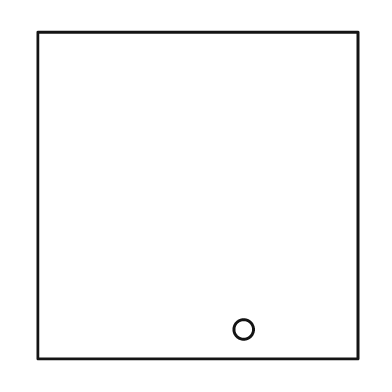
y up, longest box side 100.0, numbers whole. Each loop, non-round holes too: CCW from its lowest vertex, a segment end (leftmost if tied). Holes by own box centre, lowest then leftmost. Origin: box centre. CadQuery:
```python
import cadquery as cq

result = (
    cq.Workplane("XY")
    .moveTo(-49.0, -50.0)
    .lineTo(49.0, -50.0)
    .lineTo(49.0, 50.0)
    .lineTo(-49.0, 50.0)
    .close()
    .moveTo(14.0, -41.0)
    .circle(3.0)
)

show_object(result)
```